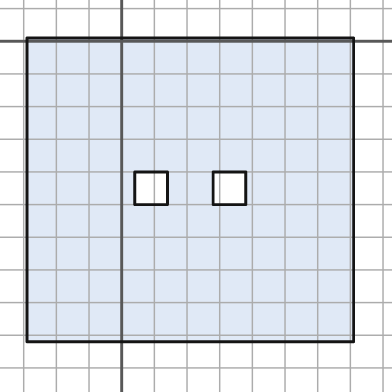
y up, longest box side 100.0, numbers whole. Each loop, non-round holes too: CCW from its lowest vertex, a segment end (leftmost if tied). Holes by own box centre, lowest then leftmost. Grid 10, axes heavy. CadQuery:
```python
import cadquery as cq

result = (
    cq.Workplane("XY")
    .moveTo(-29.0, -92.0)
    .lineTo(71.0, -92.0)
    .lineTo(71.0, 1.0)
    .lineTo(-29.0, 1.0)
    .close()
    .moveTo(4.0, -50.0)
    .lineTo(14.0, -50.0)
    .lineTo(14.0, -40.0)
    .lineTo(4.0, -40.0)
    .close()
    .moveTo(28.0, -50.0)
    .lineTo(38.0, -50.0)
    .lineTo(38.0, -40.0)
    .lineTo(28.0, -40.0)
    .close()
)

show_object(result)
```